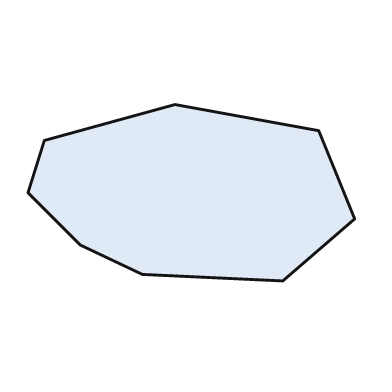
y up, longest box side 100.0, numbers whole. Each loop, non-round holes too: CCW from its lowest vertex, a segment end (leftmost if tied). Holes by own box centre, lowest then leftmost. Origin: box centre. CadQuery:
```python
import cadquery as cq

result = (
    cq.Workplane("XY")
    .moveTo(28.0, -27.0)
    .lineTo(50.0, -8.0)
    .lineTo(39.0, 19.0)
    .lineTo(-5.0, 27.0)
    .lineTo(-45.0, 16.0)
    .lineTo(-50.0, 0.0)
    .lineTo(-34.0, -16.0)
    .lineTo(-15.0, -25.0)
    .close()
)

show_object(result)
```